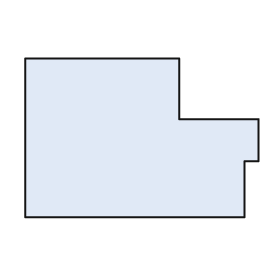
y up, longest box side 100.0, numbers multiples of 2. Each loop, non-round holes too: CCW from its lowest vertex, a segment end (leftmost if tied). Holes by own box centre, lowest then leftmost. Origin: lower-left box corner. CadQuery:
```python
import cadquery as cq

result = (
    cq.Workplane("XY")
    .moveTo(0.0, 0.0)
    .lineTo(94.0, 0.0)
    .lineTo(94.0, 24.0)
    .lineTo(100.0, 24.0)
    .lineTo(100.0, 42.0)
    .lineTo(66.0, 42.0)
    .lineTo(66.0, 68.0)
    .lineTo(0.0, 68.0)
    .close()
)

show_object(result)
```